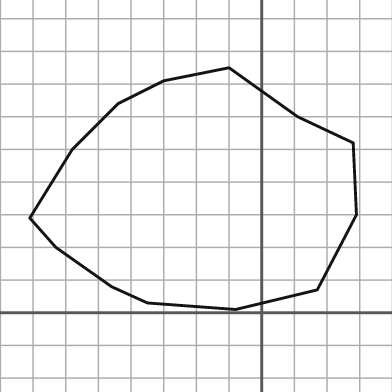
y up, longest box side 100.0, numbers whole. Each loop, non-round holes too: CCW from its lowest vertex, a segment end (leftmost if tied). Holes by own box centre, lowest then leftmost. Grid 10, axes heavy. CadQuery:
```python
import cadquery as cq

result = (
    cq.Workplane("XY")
    .moveTo(-8.0, 1.0)
    .lineTo(17.0, 7.0)
    .lineTo(29.0, 30.0)
    .lineTo(28.0, 52.0)
    .lineTo(11.0, 60.0)
    .lineTo(-10.0, 75.0)
    .lineTo(-30.0, 71.0)
    .lineTo(-44.0, 64.0)
    .lineTo(-58.0, 50.0)
    .lineTo(-71.0, 29.0)
    .lineTo(-63.0, 20.0)
    .lineTo(-46.0, 8.0)
    .lineTo(-35.0, 3.0)
    .close()
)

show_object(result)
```